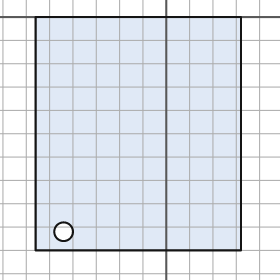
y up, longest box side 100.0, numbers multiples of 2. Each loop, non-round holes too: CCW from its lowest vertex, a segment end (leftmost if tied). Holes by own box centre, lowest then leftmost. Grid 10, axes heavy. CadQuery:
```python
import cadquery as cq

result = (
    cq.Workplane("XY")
    .moveTo(-56.0, -100.0)
    .lineTo(32.0, -100.0)
    .lineTo(32.0, 0.0)
    .lineTo(-56.0, 0.0)
    .close()
    .moveTo(-44.0, -92.0)
    .circle(4.0)
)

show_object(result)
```